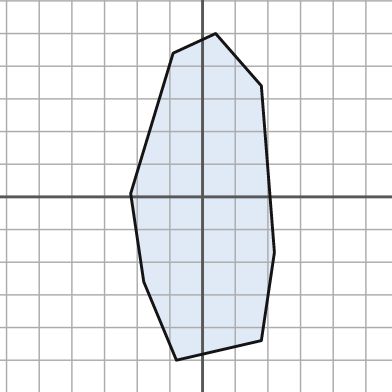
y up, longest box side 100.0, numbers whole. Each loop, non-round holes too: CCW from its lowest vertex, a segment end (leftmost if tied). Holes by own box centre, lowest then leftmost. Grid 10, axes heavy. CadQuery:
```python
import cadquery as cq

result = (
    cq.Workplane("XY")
    .moveTo(-8.0, -50.0)
    .lineTo(18.0, -44.0)
    .lineTo(22.0, -17.0)
    .lineTo(18.0, 34.0)
    .lineTo(4.0, 50.0)
    .lineTo(-9.0, 44.0)
    .lineTo(-22.0, 1.0)
    .lineTo(-18.0, -26.0)
    .close()
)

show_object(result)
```